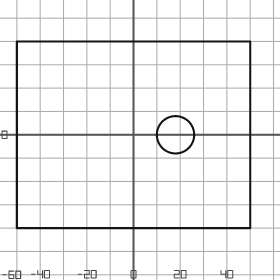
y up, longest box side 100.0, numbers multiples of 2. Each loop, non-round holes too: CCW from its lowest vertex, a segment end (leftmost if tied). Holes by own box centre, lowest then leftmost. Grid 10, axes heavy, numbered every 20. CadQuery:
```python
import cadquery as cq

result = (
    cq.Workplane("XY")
    .moveTo(-50.0, -40.0)
    .lineTo(50.0, -40.0)
    .lineTo(50.0, 40.0)
    .lineTo(-50.0, 40.0)
    .close()
    .moveTo(18.0, 0.0)
    .circle(8.0)
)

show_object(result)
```